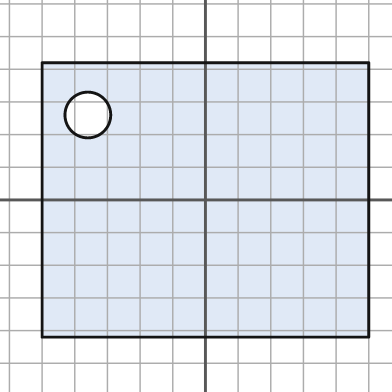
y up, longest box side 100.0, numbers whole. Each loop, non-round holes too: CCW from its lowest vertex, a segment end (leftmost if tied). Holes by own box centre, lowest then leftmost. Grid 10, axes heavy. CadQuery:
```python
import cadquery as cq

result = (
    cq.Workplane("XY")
    .moveTo(-50.0, -42.0)
    .lineTo(50.0, -42.0)
    .lineTo(50.0, 42.0)
    .lineTo(-50.0, 42.0)
    .close()
    .moveTo(-36.0, 26.0)
    .circle(7.0)
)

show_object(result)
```